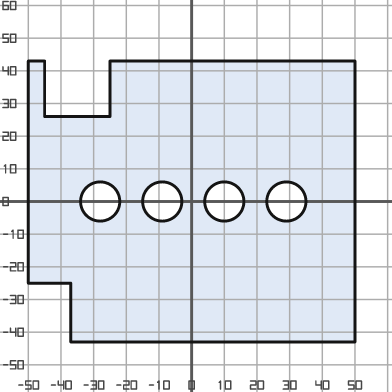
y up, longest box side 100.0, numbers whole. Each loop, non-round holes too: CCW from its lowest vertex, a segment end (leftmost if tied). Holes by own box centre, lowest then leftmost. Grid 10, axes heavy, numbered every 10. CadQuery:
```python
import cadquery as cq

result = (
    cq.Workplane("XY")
    .moveTo(-37.0, -43.0)
    .lineTo(50.0, -43.0)
    .lineTo(50.0, 43.0)
    .lineTo(-25.0, 43.0)
    .lineTo(-25.0, 26.0)
    .lineTo(-45.0, 26.0)
    .lineTo(-45.0, 43.0)
    .lineTo(-50.0, 43.0)
    .lineTo(-50.0, -25.0)
    .lineTo(-37.0, -25.0)
    .close()
    .moveTo(-28.0, 0.0)
    .circle(6.0)
    .moveTo(-9.0, 0.0)
    .circle(6.0)
    .moveTo(10.0, 0.0)
    .circle(6.0)
    .moveTo(29.0, 0.0)
    .circle(6.0)
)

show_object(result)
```